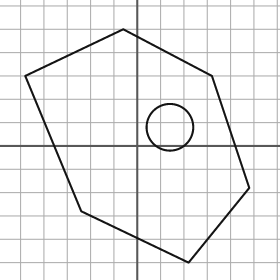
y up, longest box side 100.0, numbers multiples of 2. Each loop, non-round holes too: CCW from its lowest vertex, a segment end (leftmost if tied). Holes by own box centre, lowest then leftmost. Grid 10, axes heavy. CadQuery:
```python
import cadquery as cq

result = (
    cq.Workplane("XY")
    .moveTo(22.0, -50.0)
    .lineTo(48.0, -18.0)
    .lineTo(32.0, 30.0)
    .lineTo(-6.0, 50.0)
    .lineTo(-48.0, 30.0)
    .lineTo(-24.0, -28.0)
    .close()
    .moveTo(14.0, 8.0)
    .circle(10.0)
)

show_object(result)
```